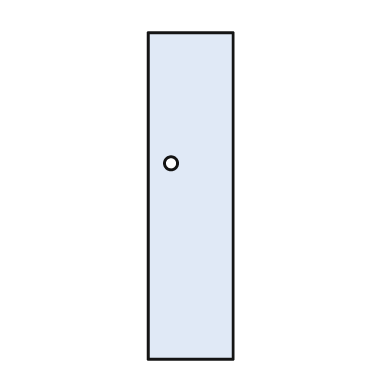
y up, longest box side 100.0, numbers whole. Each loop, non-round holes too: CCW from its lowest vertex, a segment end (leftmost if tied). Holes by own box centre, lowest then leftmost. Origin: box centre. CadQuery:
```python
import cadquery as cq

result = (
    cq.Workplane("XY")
    .moveTo(-13.0, -50.0)
    .lineTo(13.0, -50.0)
    .lineTo(13.0, 50.0)
    .lineTo(-13.0, 50.0)
    .close()
    .moveTo(-6.0, 10.0)
    .circle(2.0)
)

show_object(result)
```